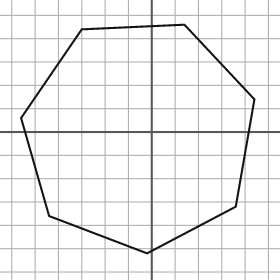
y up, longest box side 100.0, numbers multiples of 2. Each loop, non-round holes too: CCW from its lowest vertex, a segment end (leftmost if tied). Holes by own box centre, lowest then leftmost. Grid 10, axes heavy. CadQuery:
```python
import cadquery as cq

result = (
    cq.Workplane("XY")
    .moveTo(-2.0, -52.0)
    .lineTo(36.0, -32.0)
    .lineTo(44.0, 14.0)
    .lineTo(14.0, 46.0)
    .lineTo(-30.0, 44.0)
    .lineTo(-56.0, 6.0)
    .lineTo(-44.0, -36.0)
    .close()
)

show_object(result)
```